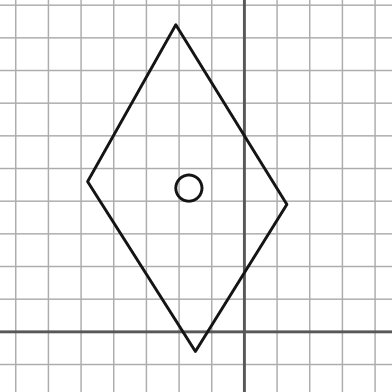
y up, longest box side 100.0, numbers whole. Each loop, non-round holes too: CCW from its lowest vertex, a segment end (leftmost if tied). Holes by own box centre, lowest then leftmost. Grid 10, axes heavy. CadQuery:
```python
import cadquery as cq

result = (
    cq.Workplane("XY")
    .moveTo(-15.0, -6.0)
    .lineTo(13.0, 39.0)
    .lineTo(-21.0, 94.0)
    .lineTo(-48.0, 46.0)
    .close()
    .moveTo(-17.0, 44.0)
    .circle(4.0)
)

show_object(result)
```